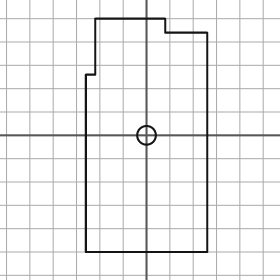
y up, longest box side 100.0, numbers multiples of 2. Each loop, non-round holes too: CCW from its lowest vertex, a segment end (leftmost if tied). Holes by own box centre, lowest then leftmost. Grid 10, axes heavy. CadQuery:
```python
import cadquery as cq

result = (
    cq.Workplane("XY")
    .moveTo(-26.0, -50.0)
    .lineTo(26.0, -50.0)
    .lineTo(26.0, 44.0)
    .lineTo(8.0, 44.0)
    .lineTo(8.0, 50.0)
    .lineTo(-22.0, 50.0)
    .lineTo(-22.0, 26.0)
    .lineTo(-26.0, 26.0)
    .close()
    .moveTo(0.0, 0.0)
    .circle(4.0)
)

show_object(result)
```